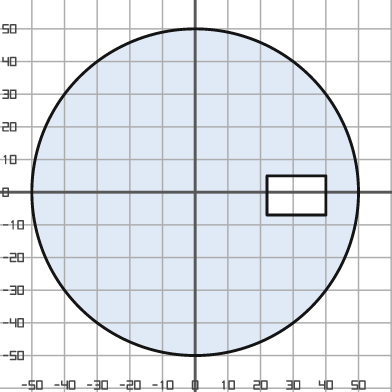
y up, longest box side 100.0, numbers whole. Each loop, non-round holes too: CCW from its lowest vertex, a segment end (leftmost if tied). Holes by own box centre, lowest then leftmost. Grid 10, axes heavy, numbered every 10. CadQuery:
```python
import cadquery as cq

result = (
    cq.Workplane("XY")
    .moveTo(0.0, 0.0)
    .circle(50.0)
    .moveTo(22.0, -7.0)
    .lineTo(40.0, -7.0)
    .lineTo(40.0, 5.0)
    .lineTo(22.0, 5.0)
    .close()
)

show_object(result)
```